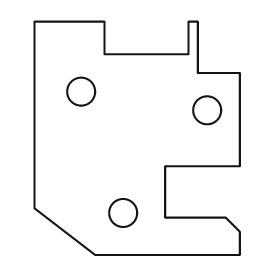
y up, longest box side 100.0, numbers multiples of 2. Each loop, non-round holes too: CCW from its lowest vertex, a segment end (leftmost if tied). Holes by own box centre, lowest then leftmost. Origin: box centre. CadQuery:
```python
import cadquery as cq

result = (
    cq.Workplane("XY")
    .moveTo(-18.0, -50.0)
    .lineTo(44.0, -50.0)
    .lineTo(44.0, -40.0)
    .lineTo(38.0, -34.0)
    .lineTo(12.0, -34.0)
    .lineTo(12.0, -12.0)
    .lineTo(44.0, -12.0)
    .lineTo(44.0, 28.0)
    .lineTo(26.0, 28.0)
    .lineTo(26.0, 50.0)
    .lineTo(22.0, 50.0)
    .lineTo(22.0, 36.0)
    .lineTo(-14.0, 36.0)
    .lineTo(-14.0, 50.0)
    .lineTo(-44.0, 50.0)
    .lineTo(-44.0, -30.0)
    .close()
    .moveTo(-6.0, -32.0)
    .circle(6.0)
    .moveTo(30.0, 12.0)
    .circle(6.0)
    .moveTo(-24.0, 20.0)
    .circle(6.0)
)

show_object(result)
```